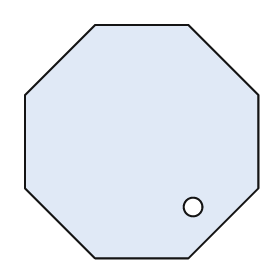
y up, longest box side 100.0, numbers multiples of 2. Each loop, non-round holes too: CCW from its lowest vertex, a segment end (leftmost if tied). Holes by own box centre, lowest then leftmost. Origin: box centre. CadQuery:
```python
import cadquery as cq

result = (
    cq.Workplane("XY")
    .moveTo(-20.0, -50.0)
    .lineTo(20.0, -50.0)
    .lineTo(50.0, -20.0)
    .lineTo(50.0, 20.0)
    .lineTo(20.0, 50.0)
    .lineTo(-20.0, 50.0)
    .lineTo(-50.0, 20.0)
    .lineTo(-50.0, -20.0)
    .close()
    .moveTo(22.0, -28.0)
    .circle(4.0)
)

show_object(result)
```